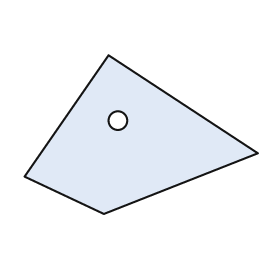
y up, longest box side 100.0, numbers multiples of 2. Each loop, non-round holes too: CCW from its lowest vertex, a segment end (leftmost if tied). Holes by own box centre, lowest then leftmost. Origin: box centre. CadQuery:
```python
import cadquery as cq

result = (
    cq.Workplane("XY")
    .moveTo(-16.0, -34.0)
    .lineTo(50.0, -8.0)
    .lineTo(-14.0, 34.0)
    .lineTo(-50.0, -18.0)
    .close()
    .moveTo(-10.0, 6.0)
    .circle(4.0)
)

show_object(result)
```